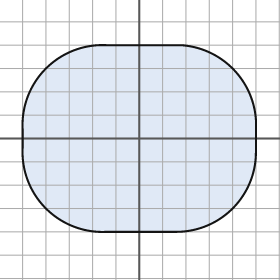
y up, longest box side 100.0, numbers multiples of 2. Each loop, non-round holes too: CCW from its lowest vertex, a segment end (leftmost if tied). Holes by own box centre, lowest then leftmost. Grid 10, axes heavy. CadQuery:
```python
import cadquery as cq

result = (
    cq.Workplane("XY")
    .moveTo(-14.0, -40.0)
    .lineTo(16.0, -40.0)
    .threePointArc((40.0, -30.0), (50.0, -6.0))
    .lineTo(50.0, 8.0)
    .threePointArc((40.0, 30.0), (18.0, 40.0))
    .lineTo(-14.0, 40.0)
    .threePointArc((-40.0, 30.0), (-50.0, 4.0))
    .lineTo(-50.0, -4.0)
    .threePointArc((-40.0, -30.0), (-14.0, -40.0))
    .close()
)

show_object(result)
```